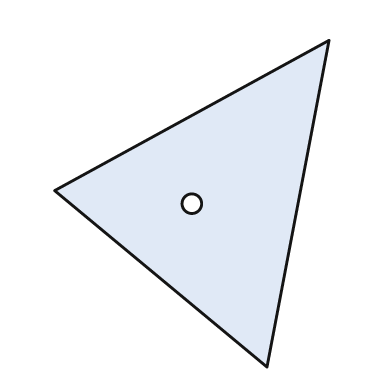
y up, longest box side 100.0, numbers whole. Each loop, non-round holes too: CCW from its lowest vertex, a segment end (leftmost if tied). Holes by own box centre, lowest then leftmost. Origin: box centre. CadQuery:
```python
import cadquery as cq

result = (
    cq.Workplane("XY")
    .moveTo(23.0, -50.0)
    .lineTo(42.0, 50.0)
    .lineTo(-42.0, 4.0)
    .close()
    .moveTo(0.0, 0.0)
    .circle(3.0)
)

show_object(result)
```